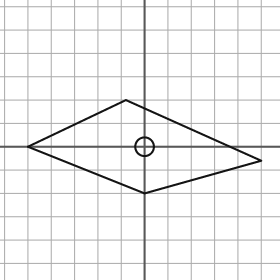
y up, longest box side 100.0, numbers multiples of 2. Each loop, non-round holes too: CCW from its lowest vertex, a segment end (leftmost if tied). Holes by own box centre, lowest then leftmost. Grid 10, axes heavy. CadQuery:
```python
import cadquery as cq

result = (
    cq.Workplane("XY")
    .moveTo(0.0, -20.0)
    .lineTo(50.0, -6.0)
    .lineTo(-8.0, 20.0)
    .lineTo(-50.0, 0.0)
    .close()
    .moveTo(0.0, 0.0)
    .circle(4.0)
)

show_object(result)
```